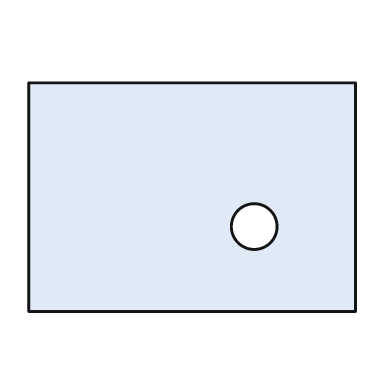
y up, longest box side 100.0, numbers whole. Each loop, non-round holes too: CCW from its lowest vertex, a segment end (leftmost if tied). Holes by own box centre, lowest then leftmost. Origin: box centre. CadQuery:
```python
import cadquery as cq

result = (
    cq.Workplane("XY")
    .moveTo(-50.0, -35.0)
    .lineTo(50.0, -35.0)
    .lineTo(50.0, 35.0)
    .lineTo(-50.0, 35.0)
    .close()
    .moveTo(19.0, -9.0)
    .circle(7.0)
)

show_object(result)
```